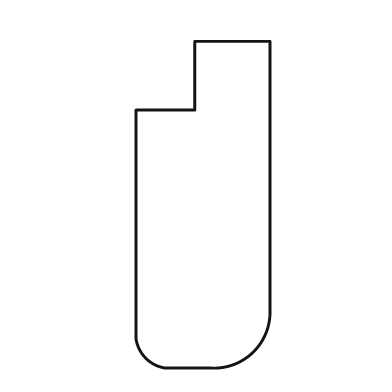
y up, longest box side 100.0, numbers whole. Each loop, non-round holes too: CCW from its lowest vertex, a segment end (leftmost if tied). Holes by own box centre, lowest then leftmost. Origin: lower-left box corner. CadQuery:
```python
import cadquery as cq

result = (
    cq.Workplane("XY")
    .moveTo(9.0, 0.0)
    .lineTo(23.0, 0.0)
    .threePointArc((36.0, 5.0), (41.0, 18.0))
    .lineTo(41.0, 100.0)
    .lineTo(18.0, 100.0)
    .lineTo(18.0, 79.0)
    .lineTo(0.0, 79.0)
    .lineTo(0.0, 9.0)
    .threePointArc((3.0, 3.0), (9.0, 0.0))
    .close()
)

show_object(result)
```